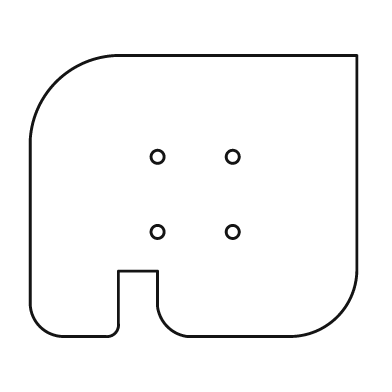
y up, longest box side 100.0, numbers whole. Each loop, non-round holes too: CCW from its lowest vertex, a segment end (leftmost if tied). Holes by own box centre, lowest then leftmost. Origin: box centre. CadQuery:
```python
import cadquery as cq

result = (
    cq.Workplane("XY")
    .moveTo(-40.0, -43.0)
    .lineTo(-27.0, -43.0)
    .threePointArc((-24.0, -42.0), (-23.0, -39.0))
    .lineTo(-23.0, -23.0)
    .lineTo(-11.0, -23.0)
    .lineTo(-11.0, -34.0)
    .threePointArc((-8.0, -40.0), (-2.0, -43.0))
    .lineTo(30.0, -43.0)
    .threePointArc((44.0, -37.0), (50.0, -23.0))
    .lineTo(50.0, 43.0)
    .lineTo(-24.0, 43.0)
    .threePointArc((-42.0, 35.0), (-50.0, 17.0))
    .lineTo(-50.0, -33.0)
    .threePointArc((-47.0, -40.0), (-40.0, -43.0))
    .close()
    .moveTo(-11.0, -11.0)
    .circle(2.0)
    .moveTo(12.0, -11.0)
    .circle(2.0)
    .moveTo(-11.0, 12.0)
    .circle(2.0)
    .moveTo(12.0, 12.0)
    .circle(2.0)
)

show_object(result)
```